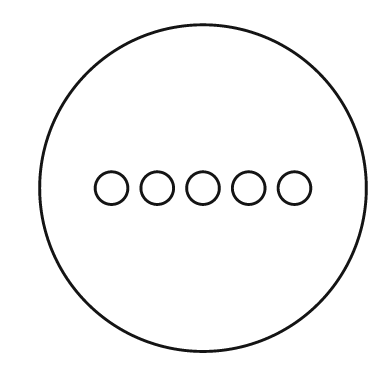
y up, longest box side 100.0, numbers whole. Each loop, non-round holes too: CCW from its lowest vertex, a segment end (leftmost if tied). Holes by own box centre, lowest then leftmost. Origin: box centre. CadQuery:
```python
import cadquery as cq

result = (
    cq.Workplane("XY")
    .moveTo(0.0, 0.0)
    .circle(50.0)
    .moveTo(-28.0, 0.0)
    .circle(5.0)
    .moveTo(-14.0, 0.0)
    .circle(5.0)
    .moveTo(0.0, 0.0)
    .circle(5.0)
    .moveTo(14.0, 0.0)
    .circle(5.0)
    .moveTo(28.0, 0.0)
    .circle(5.0)
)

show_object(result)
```